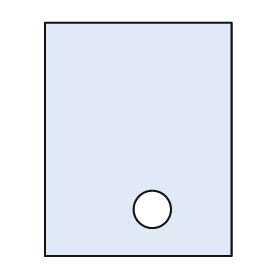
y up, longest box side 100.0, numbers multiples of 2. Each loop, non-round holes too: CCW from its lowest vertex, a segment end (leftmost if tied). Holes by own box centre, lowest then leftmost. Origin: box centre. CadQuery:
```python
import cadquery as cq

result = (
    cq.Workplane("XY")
    .moveTo(-40.0, -50.0)
    .lineTo(40.0, -50.0)
    .lineTo(40.0, 50.0)
    .lineTo(-40.0, 50.0)
    .close()
    .moveTo(6.0, -30.0)
    .circle(8.0)
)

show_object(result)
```